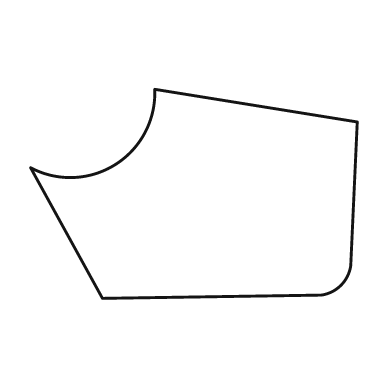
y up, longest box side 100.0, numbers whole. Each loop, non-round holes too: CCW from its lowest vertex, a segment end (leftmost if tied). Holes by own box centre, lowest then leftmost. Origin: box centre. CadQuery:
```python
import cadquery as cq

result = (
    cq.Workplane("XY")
    .moveTo(-28.0, -32.0)
    .lineTo(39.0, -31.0)
    .threePointArc((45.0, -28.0), (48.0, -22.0))
    .lineTo(50.0, 22.0)
    .lineTo(-12.0, 32.0)
    .threePointArc((-24.0, 9.0), (-50.0, 8.0))
    .close()
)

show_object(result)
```